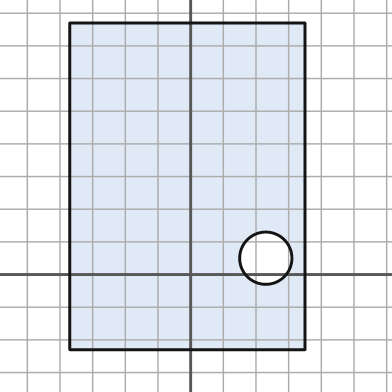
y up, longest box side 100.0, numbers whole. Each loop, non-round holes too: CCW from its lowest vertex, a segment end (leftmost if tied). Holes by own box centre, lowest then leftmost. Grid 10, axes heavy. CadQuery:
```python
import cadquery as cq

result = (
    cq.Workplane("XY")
    .moveTo(-37.0, -23.0)
    .lineTo(35.0, -23.0)
    .lineTo(35.0, 77.0)
    .lineTo(-37.0, 77.0)
    .close()
    .moveTo(23.0, 5.0)
    .circle(8.0)
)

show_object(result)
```